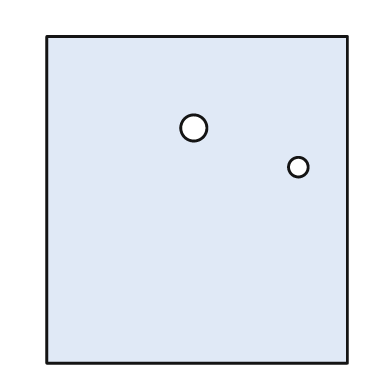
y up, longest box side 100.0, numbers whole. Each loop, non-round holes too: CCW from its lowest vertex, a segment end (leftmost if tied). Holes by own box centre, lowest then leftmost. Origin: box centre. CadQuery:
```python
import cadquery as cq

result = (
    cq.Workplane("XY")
    .moveTo(-46.0, -50.0)
    .lineTo(46.0, -50.0)
    .lineTo(46.0, 50.0)
    .lineTo(-46.0, 50.0)
    .close()
    .moveTo(31.0, 10.0)
    .circle(3.0)
    .moveTo(-1.0, 22.0)
    .circle(4.0)
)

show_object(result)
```